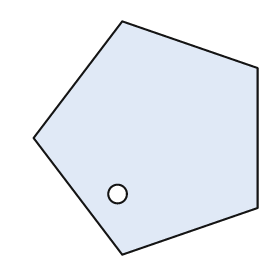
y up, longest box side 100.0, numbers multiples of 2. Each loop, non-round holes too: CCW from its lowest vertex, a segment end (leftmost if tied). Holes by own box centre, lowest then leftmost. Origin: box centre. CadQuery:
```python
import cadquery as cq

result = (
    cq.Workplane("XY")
    .moveTo(-10.0, -50.0)
    .lineTo(48.0, -30.0)
    .lineTo(48.0, 30.0)
    .lineTo(-10.0, 50.0)
    .lineTo(-48.0, 0.0)
    .close()
    .moveTo(-12.0, -24.0)
    .circle(4.0)
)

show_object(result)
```